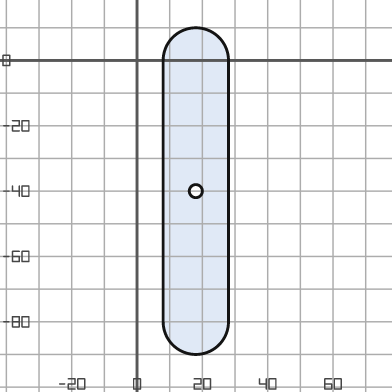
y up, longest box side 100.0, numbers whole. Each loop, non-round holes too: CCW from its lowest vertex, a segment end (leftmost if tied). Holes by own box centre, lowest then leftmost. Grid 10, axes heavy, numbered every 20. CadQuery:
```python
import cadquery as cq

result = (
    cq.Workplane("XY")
    .moveTo(8.0, -80.0)
    .threePointArc((18.0, -90.0), (28.0, -80.0))
    .lineTo(28.0, 0.0)
    .threePointArc((18.0, 10.0), (8.0, 0.0))
    .close()
    .moveTo(18.0, -40.0)
    .circle(2.0)
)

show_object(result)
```